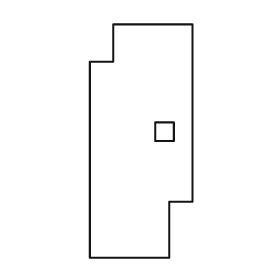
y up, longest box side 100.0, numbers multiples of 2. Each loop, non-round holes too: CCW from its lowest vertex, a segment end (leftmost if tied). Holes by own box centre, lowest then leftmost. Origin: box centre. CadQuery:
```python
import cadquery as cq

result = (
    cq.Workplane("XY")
    .moveTo(-22.0, -50.0)
    .lineTo(12.0, -50.0)
    .lineTo(12.0, -26.0)
    .lineTo(22.0, -26.0)
    .lineTo(22.0, 50.0)
    .lineTo(-12.0, 50.0)
    .lineTo(-12.0, 34.0)
    .lineTo(-22.0, 34.0)
    .close()
    .moveTo(6.0, 0.0)
    .lineTo(14.0, 0.0)
    .lineTo(14.0, 8.0)
    .lineTo(6.0, 8.0)
    .close()
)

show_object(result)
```